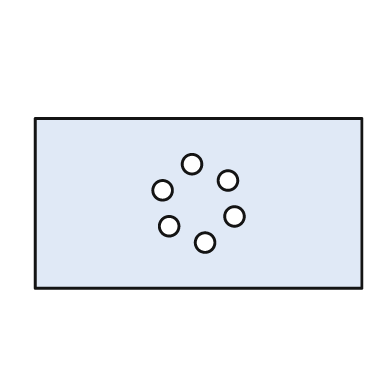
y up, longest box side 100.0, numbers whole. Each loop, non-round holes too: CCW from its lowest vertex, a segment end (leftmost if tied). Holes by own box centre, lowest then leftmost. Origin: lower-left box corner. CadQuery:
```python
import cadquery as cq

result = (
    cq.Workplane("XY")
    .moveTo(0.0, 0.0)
    .lineTo(100.0, 0.0)
    .lineTo(100.0, 52.0)
    .lineTo(0.0, 52.0)
    .close()
    .moveTo(52.0, 14.0)
    .circle(3.0)
    .moveTo(41.0, 19.0)
    .circle(3.0)
    .moveTo(61.0, 22.0)
    .circle(3.0)
    .moveTo(39.0, 30.0)
    .circle(3.0)
    .moveTo(59.0, 33.0)
    .circle(3.0)
    .moveTo(48.0, 38.0)
    .circle(3.0)
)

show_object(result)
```